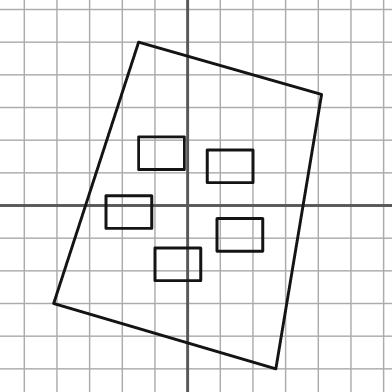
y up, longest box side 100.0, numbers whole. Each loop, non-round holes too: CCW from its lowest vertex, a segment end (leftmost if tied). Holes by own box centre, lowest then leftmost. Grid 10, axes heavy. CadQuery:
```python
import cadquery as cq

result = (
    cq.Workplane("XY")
    .moveTo(27.0, -50.0)
    .lineTo(41.0, 34.0)
    .lineTo(-15.0, 50.0)
    .lineTo(-41.0, -30.0)
    .close()
    .moveTo(-10.0, -23.0)
    .lineTo(4.0, -23.0)
    .lineTo(4.0, -13.0)
    .lineTo(-10.0, -13.0)
    .close()
    .moveTo(9.0, -14.0)
    .lineTo(23.0, -14.0)
    .lineTo(23.0, -4.0)
    .lineTo(9.0, -4.0)
    .close()
    .moveTo(-25.0, -7.0)
    .lineTo(-11.0, -7.0)
    .lineTo(-11.0, 3.0)
    .lineTo(-25.0, 3.0)
    .close()
    .moveTo(6.0, 7.0)
    .lineTo(20.0, 7.0)
    .lineTo(20.0, 17.0)
    .lineTo(6.0, 17.0)
    .close()
    .moveTo(-15.0, 11.0)
    .lineTo(-1.0, 11.0)
    .lineTo(-1.0, 21.0)
    .lineTo(-15.0, 21.0)
    .close()
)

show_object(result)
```